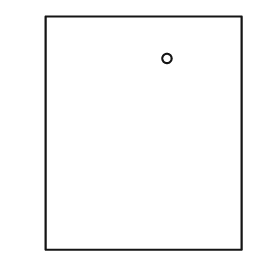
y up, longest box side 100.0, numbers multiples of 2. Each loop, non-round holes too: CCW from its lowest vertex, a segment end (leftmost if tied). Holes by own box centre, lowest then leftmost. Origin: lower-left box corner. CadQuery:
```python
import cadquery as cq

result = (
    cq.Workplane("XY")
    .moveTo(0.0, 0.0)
    .lineTo(84.0, 0.0)
    .lineTo(84.0, 100.0)
    .lineTo(0.0, 100.0)
    .close()
    .moveTo(52.0, 82.0)
    .circle(2.0)
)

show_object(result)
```